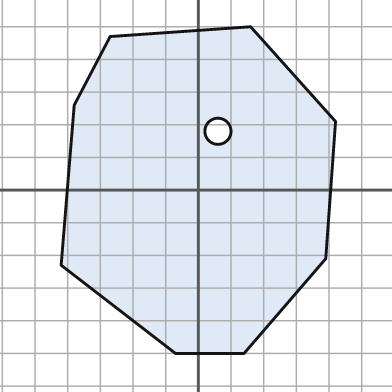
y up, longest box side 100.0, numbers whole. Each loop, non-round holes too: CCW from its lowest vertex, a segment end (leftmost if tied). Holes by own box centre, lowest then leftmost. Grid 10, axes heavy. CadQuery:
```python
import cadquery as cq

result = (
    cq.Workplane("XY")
    .moveTo(-7.0, -50.0)
    .lineTo(14.0, -50.0)
    .lineTo(39.0, -21.0)
    .lineTo(42.0, 21.0)
    .lineTo(16.0, 50.0)
    .lineTo(-27.0, 47.0)
    .lineTo(-38.0, 26.0)
    .lineTo(-42.0, -23.0)
    .close()
    .moveTo(6.0, 18.0)
    .circle(4.0)
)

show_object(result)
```